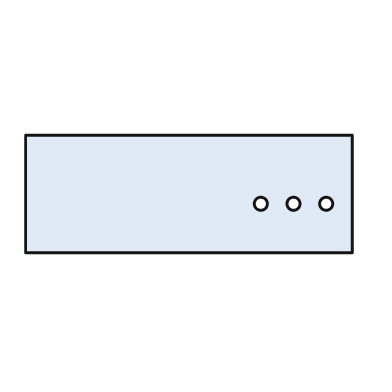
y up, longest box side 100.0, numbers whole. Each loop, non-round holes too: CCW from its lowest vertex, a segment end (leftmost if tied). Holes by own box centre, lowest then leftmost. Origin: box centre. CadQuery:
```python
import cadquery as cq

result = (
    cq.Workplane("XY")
    .moveTo(-50.0, -18.0)
    .lineTo(50.0, -18.0)
    .lineTo(50.0, 18.0)
    .lineTo(-50.0, 18.0)
    .close()
    .moveTo(22.0, -3.0)
    .circle(2.0)
    .moveTo(32.0, -3.0)
    .circle(2.0)
    .moveTo(42.0, -3.0)
    .circle(2.0)
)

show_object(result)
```